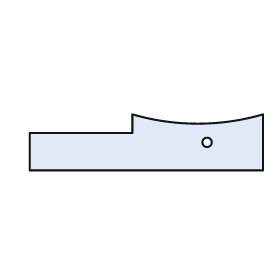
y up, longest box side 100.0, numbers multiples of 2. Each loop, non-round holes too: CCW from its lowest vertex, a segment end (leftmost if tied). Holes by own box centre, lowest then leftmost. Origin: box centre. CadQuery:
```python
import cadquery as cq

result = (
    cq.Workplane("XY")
    .moveTo(-50.0, -12.0)
    .lineTo(50.0, -12.0)
    .lineTo(50.0, 12.0)
    .threePointArc((22.0, 8.0), (-6.0, 12.0))
    .lineTo(-6.0, 4.0)
    .lineTo(-50.0, 4.0)
    .close()
    .moveTo(26.0, 0.0)
    .circle(2.0)
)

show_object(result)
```